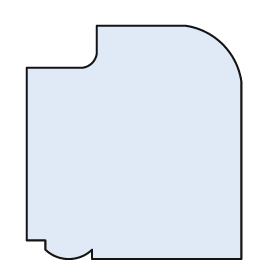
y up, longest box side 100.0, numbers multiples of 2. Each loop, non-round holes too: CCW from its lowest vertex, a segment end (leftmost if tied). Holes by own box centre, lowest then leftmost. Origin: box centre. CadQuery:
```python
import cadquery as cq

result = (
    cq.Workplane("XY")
    .moveTo(-18.0, -50.0)
    .lineTo(46.0, -50.0)
    .lineTo(46.0, 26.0)
    .threePointArc((38.0, 42.0), (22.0, 50.0))
    .lineTo(-16.0, 50.0)
    .lineTo(-16.0, 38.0)
    .threePointArc((-18.0, 34.0), (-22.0, 32.0))
    .lineTo(-46.0, 32.0)
    .lineTo(-46.0, -42.0)
    .lineTo(-38.0, -42.0)
    .lineTo(-38.0, -46.0)
    .threePointArc((-28.0, -50.0), (-18.0, -46.0))
    .close()
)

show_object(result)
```